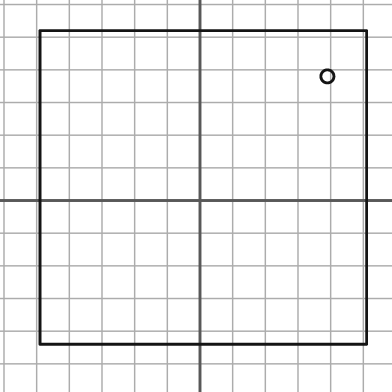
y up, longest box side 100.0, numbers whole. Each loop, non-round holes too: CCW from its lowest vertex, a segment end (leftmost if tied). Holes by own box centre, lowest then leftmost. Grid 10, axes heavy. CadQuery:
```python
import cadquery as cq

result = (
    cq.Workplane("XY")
    .moveTo(-49.0, -44.0)
    .lineTo(51.0, -44.0)
    .lineTo(51.0, 52.0)
    .lineTo(-49.0, 52.0)
    .close()
    .moveTo(39.0, 38.0)
    .circle(2.0)
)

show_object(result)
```